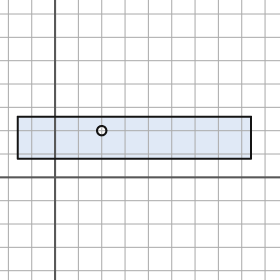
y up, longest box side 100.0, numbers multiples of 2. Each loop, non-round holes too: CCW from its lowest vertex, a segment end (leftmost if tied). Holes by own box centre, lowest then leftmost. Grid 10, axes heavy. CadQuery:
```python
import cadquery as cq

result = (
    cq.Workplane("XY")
    .moveTo(-16.0, 8.0)
    .lineTo(84.0, 8.0)
    .lineTo(84.0, 26.0)
    .lineTo(-16.0, 26.0)
    .close()
    .moveTo(20.0, 20.0)
    .circle(2.0)
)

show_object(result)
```